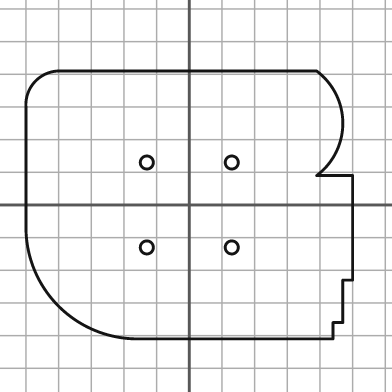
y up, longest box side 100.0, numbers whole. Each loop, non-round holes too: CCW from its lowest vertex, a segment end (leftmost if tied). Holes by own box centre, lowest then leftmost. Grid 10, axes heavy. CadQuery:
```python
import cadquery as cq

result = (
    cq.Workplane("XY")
    .moveTo(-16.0, -41.0)
    .lineTo(44.0, -41.0)
    .lineTo(44.0, -36.0)
    .lineTo(47.0, -36.0)
    .lineTo(47.0, -23.0)
    .lineTo(50.0, -23.0)
    .lineTo(50.0, 9.0)
    .lineTo(39.0, 9.0)
    .threePointArc((47.0, 25.0), (39.0, 41.0))
    .lineTo(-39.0, 41.0)
    .threePointArc((-47.0, 38.0), (-50.0, 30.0))
    .lineTo(-50.0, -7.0)
    .threePointArc((-40.0, -31.0), (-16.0, -41.0))
    .close()
    .moveTo(-13.0, -13.0)
    .circle(2.0)
    .moveTo(13.0, -13.0)
    .circle(2.0)
    .moveTo(-13.0, 13.0)
    .circle(2.0)
    .moveTo(13.0, 13.0)
    .circle(2.0)
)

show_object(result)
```